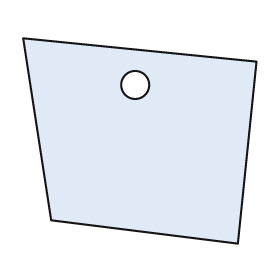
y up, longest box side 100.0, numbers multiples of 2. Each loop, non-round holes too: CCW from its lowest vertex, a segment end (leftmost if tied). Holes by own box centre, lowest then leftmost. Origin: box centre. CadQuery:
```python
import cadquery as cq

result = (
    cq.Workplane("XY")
    .moveTo(42.0, -44.0)
    .lineTo(50.0, 34.0)
    .lineTo(-50.0, 44.0)
    .lineTo(-38.0, -34.0)
    .close()
    .moveTo(-2.0, 24.0)
    .circle(6.0)
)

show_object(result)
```